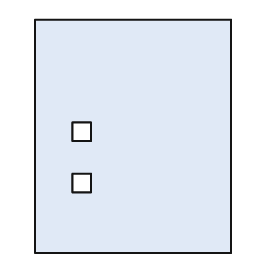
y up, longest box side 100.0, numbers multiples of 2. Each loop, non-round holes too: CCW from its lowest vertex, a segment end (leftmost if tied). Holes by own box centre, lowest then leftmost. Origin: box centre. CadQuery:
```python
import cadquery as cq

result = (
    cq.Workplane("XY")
    .moveTo(-42.0, -50.0)
    .lineTo(42.0, -50.0)
    .lineTo(42.0, 50.0)
    .lineTo(-42.0, 50.0)
    .close()
    .moveTo(-26.0, -24.0)
    .lineTo(-18.0, -24.0)
    .lineTo(-18.0, -16.0)
    .lineTo(-26.0, -16.0)
    .close()
    .moveTo(-26.0, -2.0)
    .lineTo(-18.0, -2.0)
    .lineTo(-18.0, 6.0)
    .lineTo(-26.0, 6.0)
    .close()
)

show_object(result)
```